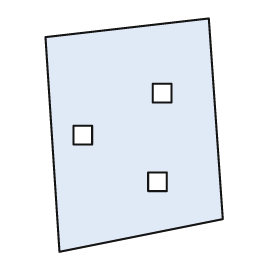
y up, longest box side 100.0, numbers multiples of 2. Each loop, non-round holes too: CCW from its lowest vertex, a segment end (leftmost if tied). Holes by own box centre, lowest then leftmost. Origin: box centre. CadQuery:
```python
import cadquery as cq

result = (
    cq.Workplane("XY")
    .moveTo(-32.0, -50.0)
    .lineTo(38.0, -36.0)
    .lineTo(32.0, 50.0)
    .lineTo(-38.0, 42.0)
    .close()
    .moveTo(6.0, -24.0)
    .lineTo(14.0, -24.0)
    .lineTo(14.0, -16.0)
    .lineTo(6.0, -16.0)
    .close()
    .moveTo(-26.0, -4.0)
    .lineTo(-18.0, -4.0)
    .lineTo(-18.0, 4.0)
    .lineTo(-26.0, 4.0)
    .close()
    .moveTo(8.0, 14.0)
    .lineTo(16.0, 14.0)
    .lineTo(16.0, 22.0)
    .lineTo(8.0, 22.0)
    .close()
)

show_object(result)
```